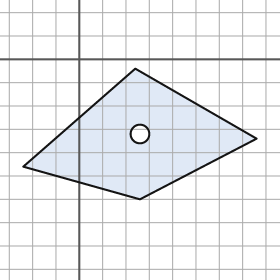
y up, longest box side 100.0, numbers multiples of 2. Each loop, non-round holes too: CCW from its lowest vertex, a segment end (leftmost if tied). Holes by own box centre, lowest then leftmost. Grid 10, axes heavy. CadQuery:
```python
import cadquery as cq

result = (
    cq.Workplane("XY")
    .moveTo(26.0, -60.0)
    .lineTo(76.0, -34.0)
    .lineTo(24.0, -4.0)
    .lineTo(-24.0, -46.0)
    .close()
    .moveTo(26.0, -32.0)
    .circle(4.0)
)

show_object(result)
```